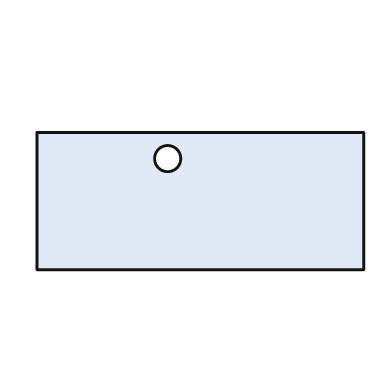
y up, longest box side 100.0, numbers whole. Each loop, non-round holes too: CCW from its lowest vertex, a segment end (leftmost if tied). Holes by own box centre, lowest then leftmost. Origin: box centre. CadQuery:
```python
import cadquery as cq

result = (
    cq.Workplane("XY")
    .moveTo(-50.0, -21.0)
    .lineTo(50.0, -21.0)
    .lineTo(50.0, 21.0)
    .lineTo(-50.0, 21.0)
    .close()
    .moveTo(-10.0, 13.0)
    .circle(4.0)
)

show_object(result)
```